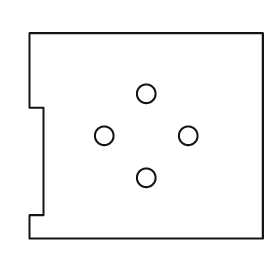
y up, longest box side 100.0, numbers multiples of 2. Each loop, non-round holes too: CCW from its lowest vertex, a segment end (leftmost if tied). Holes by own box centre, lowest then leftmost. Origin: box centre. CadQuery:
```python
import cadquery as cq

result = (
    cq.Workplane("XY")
    .moveTo(-50.0, -44.0)
    .lineTo(50.0, -44.0)
    .lineTo(50.0, 44.0)
    .lineTo(-50.0, 44.0)
    .lineTo(-50.0, 12.0)
    .lineTo(-44.0, 12.0)
    .lineTo(-44.0, -34.0)
    .lineTo(-50.0, -34.0)
    .close()
    .moveTo(0.0, -18.0)
    .circle(4.0)
    .moveTo(-18.0, 0.0)
    .circle(4.0)
    .moveTo(18.0, 0.0)
    .circle(4.0)
    .moveTo(0.0, 18.0)
    .circle(4.0)
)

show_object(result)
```